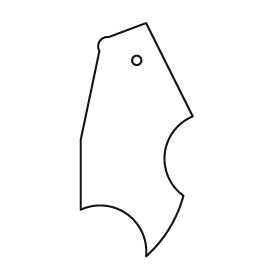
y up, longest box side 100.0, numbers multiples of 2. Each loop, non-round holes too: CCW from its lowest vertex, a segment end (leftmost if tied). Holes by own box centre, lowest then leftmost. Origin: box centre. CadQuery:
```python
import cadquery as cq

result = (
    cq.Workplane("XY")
    .moveTo(4.0, -50.0)
    .threePointArc((14.0, -38.0), (20.0, -24.0))
    .threePointArc((12.0, -6.0), (24.0, 10.0))
    .lineTo(4.0, 50.0)
    .lineTo(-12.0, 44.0)
    .threePointArc((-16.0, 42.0), (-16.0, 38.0))
    .lineTo(-24.0, 0.0)
    .lineTo(-24.0, -30.0)
    .threePointArc((-4.0, -32.0), (4.0, -50.0))
    .close()
    .moveTo(0.0, 34.0)
    .circle(2.0)
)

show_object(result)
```